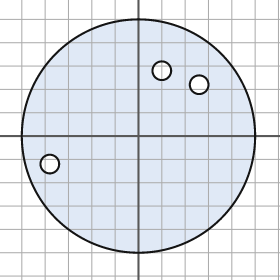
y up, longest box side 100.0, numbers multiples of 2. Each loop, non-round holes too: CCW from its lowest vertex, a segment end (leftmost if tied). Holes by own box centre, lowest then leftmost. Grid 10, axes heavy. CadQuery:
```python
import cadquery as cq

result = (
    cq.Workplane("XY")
    .moveTo(0.0, 0.0)
    .circle(50.0)
    .moveTo(-38.0, -12.0)
    .circle(4.0)
    .moveTo(26.0, 22.0)
    .circle(4.0)
    .moveTo(10.0, 28.0)
    .circle(4.0)
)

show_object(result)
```